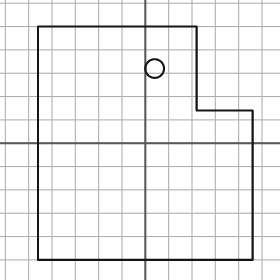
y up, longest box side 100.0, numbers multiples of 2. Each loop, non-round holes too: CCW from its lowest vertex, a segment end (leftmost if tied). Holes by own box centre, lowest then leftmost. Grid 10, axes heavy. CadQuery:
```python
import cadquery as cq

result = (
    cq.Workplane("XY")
    .moveTo(-46.0, -50.0)
    .lineTo(46.0, -50.0)
    .lineTo(46.0, 14.0)
    .lineTo(22.0, 14.0)
    .lineTo(22.0, 50.0)
    .lineTo(-46.0, 50.0)
    .close()
    .moveTo(4.0, 32.0)
    .circle(4.0)
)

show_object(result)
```